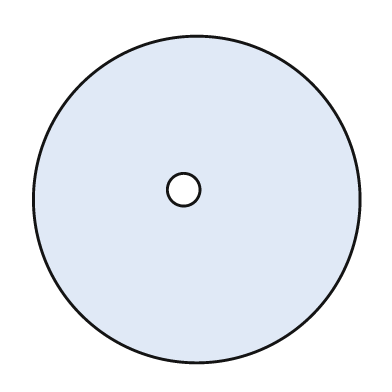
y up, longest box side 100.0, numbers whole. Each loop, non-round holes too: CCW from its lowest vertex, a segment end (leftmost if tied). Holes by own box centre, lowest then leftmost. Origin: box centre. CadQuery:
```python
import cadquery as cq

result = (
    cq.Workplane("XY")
    .moveTo(0.0, 0.0)
    .circle(50.0)
    .moveTo(-4.0, 3.0)
    .circle(5.0)
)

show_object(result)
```